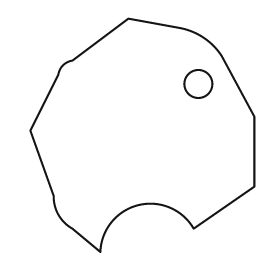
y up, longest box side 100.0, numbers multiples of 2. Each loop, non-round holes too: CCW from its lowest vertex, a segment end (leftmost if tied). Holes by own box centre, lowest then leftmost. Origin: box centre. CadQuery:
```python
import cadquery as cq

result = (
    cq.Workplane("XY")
    .moveTo(-18.0, -50.0)
    .threePointArc((-2.0, -30.0), (22.0, -40.0))
    .lineTo(48.0, -22.0)
    .lineTo(48.0, 8.0)
    .lineTo(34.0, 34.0)
    .threePointArc((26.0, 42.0), (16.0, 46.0))
    .lineTo(-6.0, 50.0)
    .lineTo(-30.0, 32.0)
    .threePointArc((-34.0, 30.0), (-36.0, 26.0))
    .lineTo(-48.0, 2.0)
    .lineTo(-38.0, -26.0)
    .threePointArc((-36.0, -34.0), (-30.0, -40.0))
    .close()
    .moveTo(24.0, 22.0)
    .circle(6.0)
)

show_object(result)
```